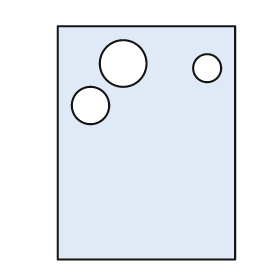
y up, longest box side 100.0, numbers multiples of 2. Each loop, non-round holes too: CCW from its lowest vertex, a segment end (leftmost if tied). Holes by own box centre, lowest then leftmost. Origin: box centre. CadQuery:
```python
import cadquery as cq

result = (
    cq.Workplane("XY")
    .moveTo(-38.0, -50.0)
    .lineTo(38.0, -50.0)
    .lineTo(38.0, 50.0)
    .lineTo(-38.0, 50.0)
    .close()
    .moveTo(-24.0, 16.0)
    .circle(8.0)
    .moveTo(26.0, 32.0)
    .circle(6.0)
    .moveTo(-10.0, 34.0)
    .circle(10.0)
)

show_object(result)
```